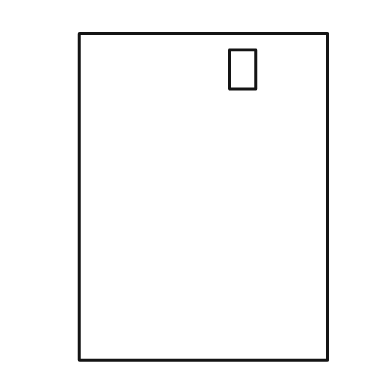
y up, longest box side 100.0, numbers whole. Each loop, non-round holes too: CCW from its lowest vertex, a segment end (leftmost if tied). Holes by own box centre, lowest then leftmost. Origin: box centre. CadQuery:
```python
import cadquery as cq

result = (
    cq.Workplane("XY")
    .moveTo(-38.0, -50.0)
    .lineTo(38.0, -50.0)
    .lineTo(38.0, 50.0)
    .lineTo(-38.0, 50.0)
    .close()
    .moveTo(8.0, 33.0)
    .lineTo(16.0, 33.0)
    .lineTo(16.0, 45.0)
    .lineTo(8.0, 45.0)
    .close()
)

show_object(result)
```